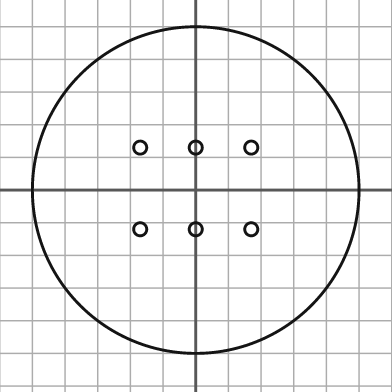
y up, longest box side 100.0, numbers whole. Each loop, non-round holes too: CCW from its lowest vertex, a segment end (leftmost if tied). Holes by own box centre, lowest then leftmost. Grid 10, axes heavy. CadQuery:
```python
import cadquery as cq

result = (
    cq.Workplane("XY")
    .moveTo(0.0, 0.0)
    .circle(50.0)
    .moveTo(-17.0, -12.0)
    .circle(2.0)
    .moveTo(0.0, -12.0)
    .circle(2.0)
    .moveTo(17.0, -12.0)
    .circle(2.0)
    .moveTo(-17.0, 13.0)
    .circle(2.0)
    .moveTo(0.0, 13.0)
    .circle(2.0)
    .moveTo(17.0, 13.0)
    .circle(2.0)
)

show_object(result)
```